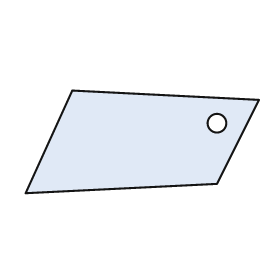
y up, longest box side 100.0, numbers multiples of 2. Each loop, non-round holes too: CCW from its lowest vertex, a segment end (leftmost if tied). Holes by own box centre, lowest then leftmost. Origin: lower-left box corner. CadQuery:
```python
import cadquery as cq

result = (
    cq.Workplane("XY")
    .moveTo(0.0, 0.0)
    .lineTo(82.0, 4.0)
    .lineTo(100.0, 40.0)
    .lineTo(20.0, 44.0)
    .close()
    .moveTo(82.0, 30.0)
    .circle(4.0)
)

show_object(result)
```